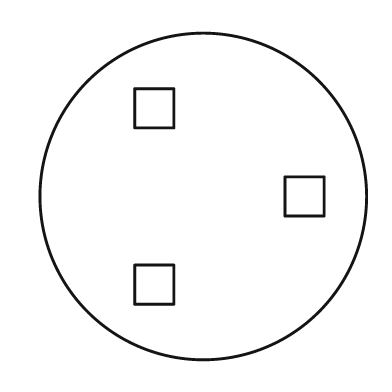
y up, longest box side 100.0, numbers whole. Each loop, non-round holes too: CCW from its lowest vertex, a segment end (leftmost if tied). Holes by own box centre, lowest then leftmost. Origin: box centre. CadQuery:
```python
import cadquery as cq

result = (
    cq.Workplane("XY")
    .moveTo(0.0, 0.0)
    .circle(50.0)
    .moveTo(-21.0, -33.0)
    .lineTo(-9.0, -33.0)
    .lineTo(-9.0, -21.0)
    .lineTo(-21.0, -21.0)
    .close()
    .moveTo(25.0, -6.0)
    .lineTo(37.0, -6.0)
    .lineTo(37.0, 6.0)
    .lineTo(25.0, 6.0)
    .close()
    .moveTo(-21.0, 21.0)
    .lineTo(-9.0, 21.0)
    .lineTo(-9.0, 33.0)
    .lineTo(-21.0, 33.0)
    .close()
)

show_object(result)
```